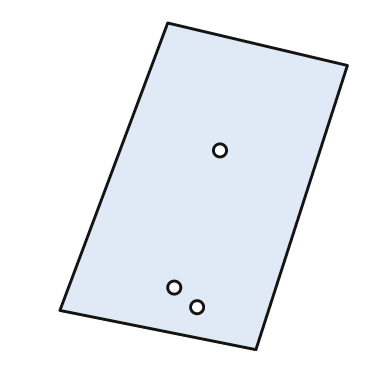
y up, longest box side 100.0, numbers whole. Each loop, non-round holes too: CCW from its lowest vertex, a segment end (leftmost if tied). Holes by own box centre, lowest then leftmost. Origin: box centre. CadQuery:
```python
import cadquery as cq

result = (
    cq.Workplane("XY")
    .moveTo(16.0, -50.0)
    .lineTo(44.0, 37.0)
    .lineTo(-11.0, 50.0)
    .lineTo(-44.0, -38.0)
    .close()
    .moveTo(-2.0, -37.0)
    .circle(2.0)
    .moveTo(-9.0, -31.0)
    .circle(2.0)
    .moveTo(5.0, 11.0)
    .circle(2.0)
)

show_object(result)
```